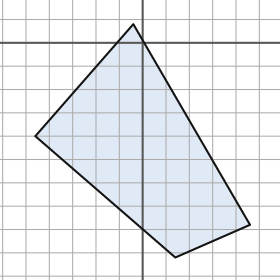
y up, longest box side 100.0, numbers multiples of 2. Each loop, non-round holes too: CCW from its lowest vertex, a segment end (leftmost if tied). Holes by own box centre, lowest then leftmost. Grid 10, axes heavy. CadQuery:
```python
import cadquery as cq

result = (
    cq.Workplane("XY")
    .moveTo(14.0, -92.0)
    .lineTo(46.0, -78.0)
    .lineTo(-4.0, 8.0)
    .lineTo(-46.0, -40.0)
    .close()
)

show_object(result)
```